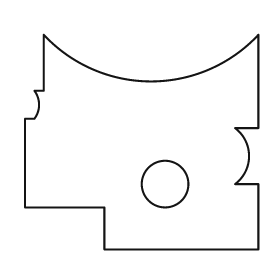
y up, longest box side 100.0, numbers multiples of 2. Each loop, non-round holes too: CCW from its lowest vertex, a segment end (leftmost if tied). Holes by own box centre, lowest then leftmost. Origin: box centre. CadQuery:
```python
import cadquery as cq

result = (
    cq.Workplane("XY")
    .moveTo(-16.0, -46.0)
    .lineTo(50.0, -46.0)
    .lineTo(50.0, -18.0)
    .lineTo(40.0, -18.0)
    .threePointArc((46.0, -6.0), (40.0, 6.0))
    .lineTo(50.0, 6.0)
    .lineTo(50.0, 46.0)
    .threePointArc((4.0, 26.0), (-42.0, 46.0))
    .lineTo(-42.0, 22.0)
    .lineTo(-46.0, 22.0)
    .threePointArc((-44.0, 16.0), (-46.0, 10.0))
    .lineTo(-50.0, 10.0)
    .lineTo(-50.0, -28.0)
    .lineTo(-16.0, -28.0)
    .close()
    .moveTo(10.0, -18.0)
    .circle(10.0)
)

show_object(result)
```